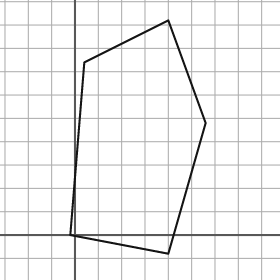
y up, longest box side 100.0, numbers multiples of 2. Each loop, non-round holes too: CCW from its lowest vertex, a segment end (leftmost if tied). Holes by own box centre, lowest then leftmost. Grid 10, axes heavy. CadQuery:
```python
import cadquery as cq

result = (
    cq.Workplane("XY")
    .moveTo(40.0, -8.0)
    .lineTo(56.0, 48.0)
    .lineTo(40.0, 92.0)
    .lineTo(4.0, 74.0)
    .lineTo(-2.0, 0.0)
    .close()
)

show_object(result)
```